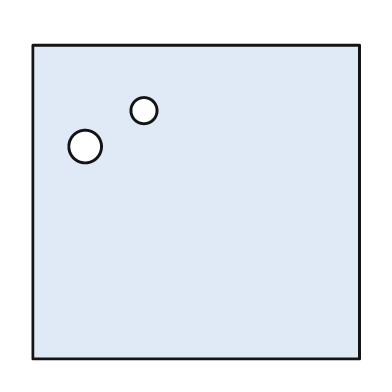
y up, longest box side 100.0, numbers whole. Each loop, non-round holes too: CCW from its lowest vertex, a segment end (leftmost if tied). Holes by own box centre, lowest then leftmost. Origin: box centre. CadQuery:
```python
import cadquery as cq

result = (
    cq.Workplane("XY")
    .moveTo(-50.0, -48.0)
    .lineTo(50.0, -48.0)
    .lineTo(50.0, 48.0)
    .lineTo(-50.0, 48.0)
    .close()
    .moveTo(-34.0, 17.0)
    .circle(5.0)
    .moveTo(-16.0, 28.0)
    .circle(4.0)
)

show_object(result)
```